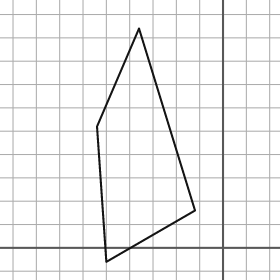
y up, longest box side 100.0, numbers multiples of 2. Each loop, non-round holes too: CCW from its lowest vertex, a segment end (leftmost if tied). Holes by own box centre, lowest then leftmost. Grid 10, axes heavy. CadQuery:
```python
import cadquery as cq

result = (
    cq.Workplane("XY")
    .moveTo(-50.0, -6.0)
    .lineTo(-12.0, 16.0)
    .lineTo(-36.0, 94.0)
    .lineTo(-54.0, 52.0)
    .close()
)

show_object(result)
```